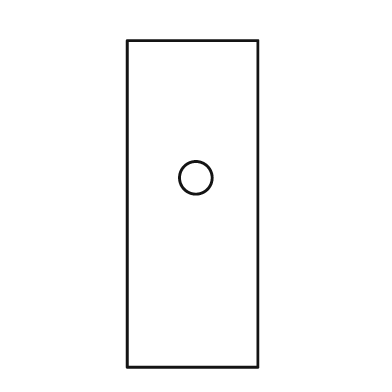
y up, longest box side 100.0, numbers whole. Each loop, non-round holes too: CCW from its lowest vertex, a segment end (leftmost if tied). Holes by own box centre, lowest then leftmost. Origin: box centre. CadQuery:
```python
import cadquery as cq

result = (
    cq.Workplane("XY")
    .moveTo(-20.0, -50.0)
    .lineTo(20.0, -50.0)
    .lineTo(20.0, 50.0)
    .lineTo(-20.0, 50.0)
    .close()
    .moveTo(1.0, 8.0)
    .circle(5.0)
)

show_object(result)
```